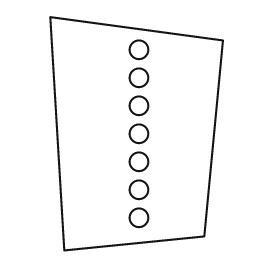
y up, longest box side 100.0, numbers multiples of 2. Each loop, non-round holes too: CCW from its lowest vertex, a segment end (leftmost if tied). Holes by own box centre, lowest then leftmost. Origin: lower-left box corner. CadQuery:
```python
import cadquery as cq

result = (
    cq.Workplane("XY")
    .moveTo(6.0, 0.0)
    .lineTo(66.0, 6.0)
    .lineTo(74.0, 90.0)
    .lineTo(0.0, 100.0)
    .close()
    .moveTo(38.0, 14.0)
    .circle(4.0)
    .moveTo(38.0, 26.0)
    .circle(4.0)
    .moveTo(38.0, 38.0)
    .circle(4.0)
    .moveTo(38.0, 50.0)
    .circle(4.0)
    .moveTo(38.0, 62.0)
    .circle(4.0)
    .moveTo(38.0, 74.0)
    .circle(4.0)
    .moveTo(38.0, 86.0)
    .circle(4.0)
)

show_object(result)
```